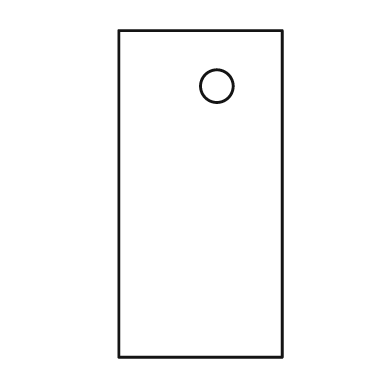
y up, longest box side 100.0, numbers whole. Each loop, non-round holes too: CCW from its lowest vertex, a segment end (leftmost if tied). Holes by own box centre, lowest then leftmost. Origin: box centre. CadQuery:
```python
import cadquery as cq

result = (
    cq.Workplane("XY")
    .moveTo(-25.0, -50.0)
    .lineTo(25.0, -50.0)
    .lineTo(25.0, 50.0)
    .lineTo(-25.0, 50.0)
    .close()
    .moveTo(5.0, 33.0)
    .circle(5.0)
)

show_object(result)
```